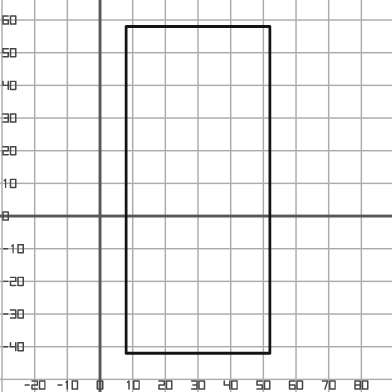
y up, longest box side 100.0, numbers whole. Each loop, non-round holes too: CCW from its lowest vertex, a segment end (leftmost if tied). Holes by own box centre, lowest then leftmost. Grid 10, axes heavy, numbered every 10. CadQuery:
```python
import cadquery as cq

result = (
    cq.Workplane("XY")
    .moveTo(8.0, -42.0)
    .lineTo(52.0, -42.0)
    .lineTo(52.0, 58.0)
    .lineTo(8.0, 58.0)
    .close()
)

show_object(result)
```